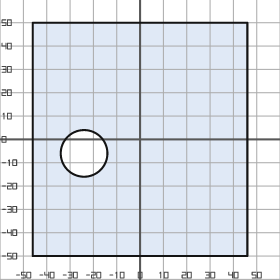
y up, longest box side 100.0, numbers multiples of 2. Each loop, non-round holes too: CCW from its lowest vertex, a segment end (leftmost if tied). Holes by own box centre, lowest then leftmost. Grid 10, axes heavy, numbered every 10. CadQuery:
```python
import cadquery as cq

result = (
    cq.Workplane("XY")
    .moveTo(-46.0, -50.0)
    .lineTo(46.0, -50.0)
    .lineTo(46.0, 50.0)
    .lineTo(-46.0, 50.0)
    .close()
    .moveTo(-24.0, -6.0)
    .circle(10.0)
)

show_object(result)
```